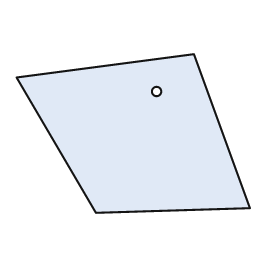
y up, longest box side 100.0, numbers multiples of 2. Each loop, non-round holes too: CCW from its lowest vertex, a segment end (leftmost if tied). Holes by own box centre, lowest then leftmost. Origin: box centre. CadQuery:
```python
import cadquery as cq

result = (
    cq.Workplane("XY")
    .moveTo(-16.0, -34.0)
    .lineTo(50.0, -32.0)
    .lineTo(26.0, 34.0)
    .lineTo(-50.0, 24.0)
    .close()
    .moveTo(10.0, 18.0)
    .circle(2.0)
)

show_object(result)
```